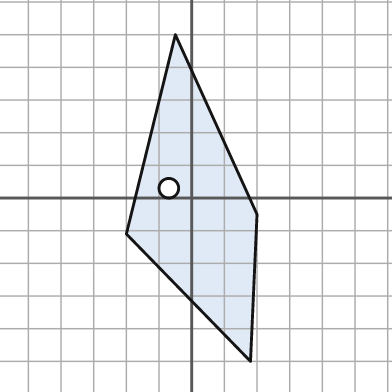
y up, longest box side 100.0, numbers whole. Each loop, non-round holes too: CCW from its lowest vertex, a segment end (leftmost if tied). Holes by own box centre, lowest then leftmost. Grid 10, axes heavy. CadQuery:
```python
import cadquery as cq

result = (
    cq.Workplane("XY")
    .moveTo(18.0, -50.0)
    .lineTo(20.0, -5.0)
    .lineTo(-5.0, 50.0)
    .lineTo(-20.0, -11.0)
    .close()
    .moveTo(-7.0, 3.0)
    .circle(3.0)
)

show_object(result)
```